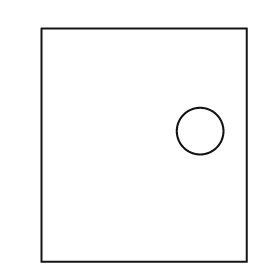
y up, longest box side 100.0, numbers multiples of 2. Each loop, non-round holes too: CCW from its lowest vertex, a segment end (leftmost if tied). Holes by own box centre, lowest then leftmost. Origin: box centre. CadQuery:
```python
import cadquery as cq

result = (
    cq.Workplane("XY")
    .moveTo(-44.0, -50.0)
    .lineTo(44.0, -50.0)
    .lineTo(44.0, 50.0)
    .lineTo(-44.0, 50.0)
    .close()
    .moveTo(24.0, 6.0)
    .circle(10.0)
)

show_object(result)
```